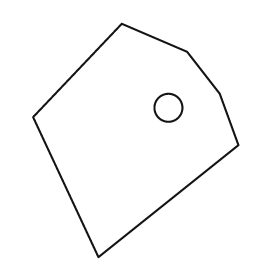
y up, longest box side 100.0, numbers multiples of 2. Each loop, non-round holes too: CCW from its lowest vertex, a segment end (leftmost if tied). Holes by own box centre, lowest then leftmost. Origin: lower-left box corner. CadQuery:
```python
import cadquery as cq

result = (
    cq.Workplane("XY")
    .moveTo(28.0, 0.0)
    .lineTo(88.0, 48.0)
    .lineTo(80.0, 70.0)
    .lineTo(66.0, 88.0)
    .lineTo(38.0, 100.0)
    .lineTo(0.0, 60.0)
    .close()
    .moveTo(58.0, 64.0)
    .circle(6.0)
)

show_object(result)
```